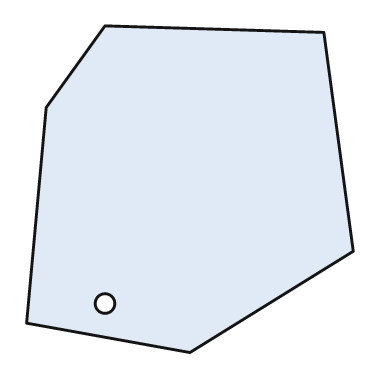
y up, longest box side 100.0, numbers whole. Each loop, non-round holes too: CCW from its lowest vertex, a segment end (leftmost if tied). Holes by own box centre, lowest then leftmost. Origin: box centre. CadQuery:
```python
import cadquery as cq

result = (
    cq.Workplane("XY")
    .moveTo(0.0, -50.0)
    .lineTo(50.0, -19.0)
    .lineTo(41.0, 48.0)
    .lineTo(-26.0, 50.0)
    .lineTo(-44.0, 25.0)
    .lineTo(-50.0, -41.0)
    .close()
    .moveTo(-26.0, -35.0)
    .circle(3.0)
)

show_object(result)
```